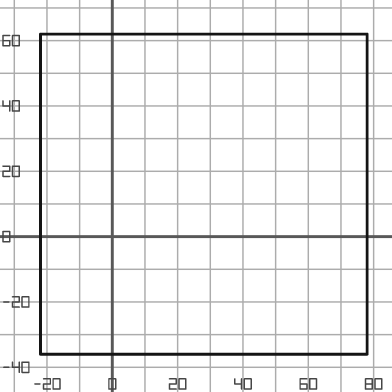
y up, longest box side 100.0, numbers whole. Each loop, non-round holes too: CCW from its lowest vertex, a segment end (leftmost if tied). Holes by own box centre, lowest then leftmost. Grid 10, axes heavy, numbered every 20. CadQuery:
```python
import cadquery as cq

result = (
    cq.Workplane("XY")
    .moveTo(-22.0, -36.0)
    .lineTo(78.0, -36.0)
    .lineTo(78.0, 62.0)
    .lineTo(-22.0, 62.0)
    .close()
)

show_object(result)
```